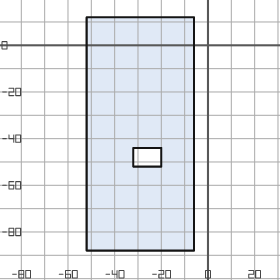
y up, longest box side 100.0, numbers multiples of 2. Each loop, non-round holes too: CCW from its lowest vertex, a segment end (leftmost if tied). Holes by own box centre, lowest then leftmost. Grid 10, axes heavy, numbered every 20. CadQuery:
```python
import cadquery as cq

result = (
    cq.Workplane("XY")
    .moveTo(-52.0, -88.0)
    .lineTo(-6.0, -88.0)
    .lineTo(-6.0, 12.0)
    .lineTo(-52.0, 12.0)
    .close()
    .moveTo(-32.0, -52.0)
    .lineTo(-20.0, -52.0)
    .lineTo(-20.0, -44.0)
    .lineTo(-32.0, -44.0)
    .close()
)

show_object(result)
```